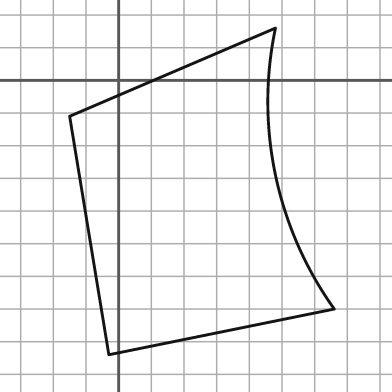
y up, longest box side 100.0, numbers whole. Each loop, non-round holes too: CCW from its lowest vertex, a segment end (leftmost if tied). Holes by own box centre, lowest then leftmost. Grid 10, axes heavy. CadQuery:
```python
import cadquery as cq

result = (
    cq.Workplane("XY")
    .moveTo(-3.0, -84.0)
    .lineTo(66.0, -70.0)
    .threePointArc((48.0, -29.0), (48.0, 16.0))
    .lineTo(-15.0, -11.0)
    .close()
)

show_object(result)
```